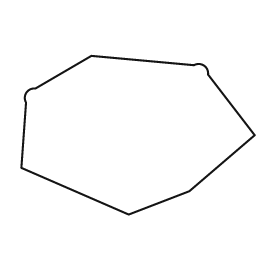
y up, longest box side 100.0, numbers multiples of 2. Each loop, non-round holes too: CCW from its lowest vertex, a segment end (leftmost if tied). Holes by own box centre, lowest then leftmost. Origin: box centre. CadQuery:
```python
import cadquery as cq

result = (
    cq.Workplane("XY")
    .moveTo(-4.0, -34.0)
    .lineTo(22.0, -24.0)
    .lineTo(50.0, 0.0)
    .lineTo(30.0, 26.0)
    .threePointArc((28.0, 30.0), (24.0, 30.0))
    .lineTo(-20.0, 34.0)
    .lineTo(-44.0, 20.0)
    .threePointArc((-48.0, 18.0), (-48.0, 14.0))
    .lineTo(-50.0, -14.0)
    .close()
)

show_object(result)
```